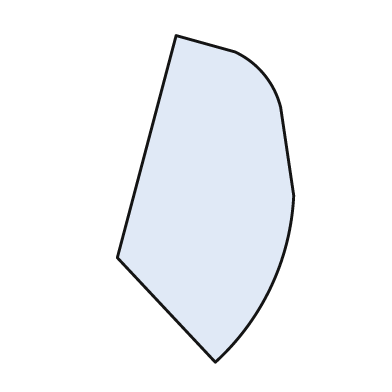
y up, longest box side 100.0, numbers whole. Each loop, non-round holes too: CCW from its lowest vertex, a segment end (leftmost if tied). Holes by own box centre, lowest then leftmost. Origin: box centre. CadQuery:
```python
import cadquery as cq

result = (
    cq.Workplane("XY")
    .moveTo(3.0, -50.0)
    .threePointArc((20.0, -27.0), (27.0, 1.0))
    .lineTo(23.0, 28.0)
    .threePointArc((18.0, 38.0), (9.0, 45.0))
    .lineTo(-9.0, 50.0)
    .lineTo(-27.0, -18.0)
    .close()
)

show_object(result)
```